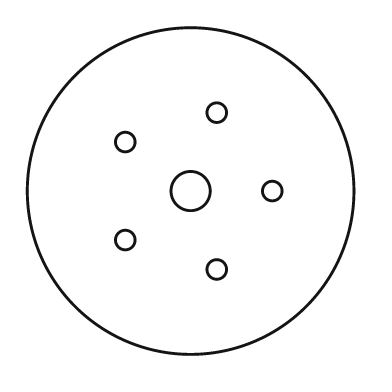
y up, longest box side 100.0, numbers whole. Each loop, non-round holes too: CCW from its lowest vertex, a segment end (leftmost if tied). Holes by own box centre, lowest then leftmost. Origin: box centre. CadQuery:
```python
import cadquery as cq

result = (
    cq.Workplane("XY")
    .moveTo(0.0, 0.0)
    .circle(50.0)
    .moveTo(8.0, -24.0)
    .circle(3.0)
    .moveTo(-20.0, -15.0)
    .circle(3.0)
    .moveTo(0.0, 0.0)
    .circle(6.0)
    .moveTo(25.0, 0.0)
    .circle(3.0)
    .moveTo(-20.0, 15.0)
    .circle(3.0)
    .moveTo(8.0, 24.0)
    .circle(3.0)
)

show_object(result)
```